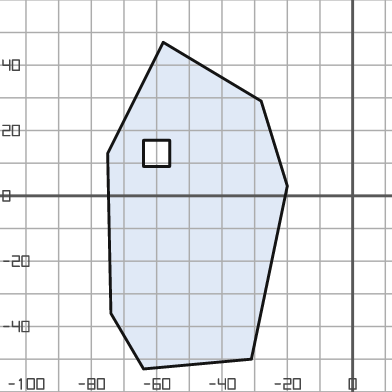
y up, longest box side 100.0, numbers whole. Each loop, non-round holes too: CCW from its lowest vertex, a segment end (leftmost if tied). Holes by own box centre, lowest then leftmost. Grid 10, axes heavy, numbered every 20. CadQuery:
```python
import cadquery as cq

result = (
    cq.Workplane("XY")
    .moveTo(-64.0, -53.0)
    .lineTo(-31.0, -50.0)
    .lineTo(-20.0, 3.0)
    .lineTo(-28.0, 29.0)
    .lineTo(-58.0, 47.0)
    .lineTo(-75.0, 13.0)
    .lineTo(-74.0, -36.0)
    .close()
    .moveTo(-64.0, 9.0)
    .lineTo(-56.0, 9.0)
    .lineTo(-56.0, 17.0)
    .lineTo(-64.0, 17.0)
    .close()
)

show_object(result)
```